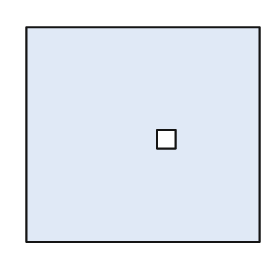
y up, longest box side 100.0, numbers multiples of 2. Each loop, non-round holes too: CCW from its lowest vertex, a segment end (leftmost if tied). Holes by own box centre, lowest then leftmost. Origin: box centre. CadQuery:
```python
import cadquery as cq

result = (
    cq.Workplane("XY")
    .moveTo(-50.0, -46.0)
    .lineTo(50.0, -46.0)
    .lineTo(50.0, 46.0)
    .lineTo(-50.0, 46.0)
    .close()
    .moveTo(6.0, -6.0)
    .lineTo(14.0, -6.0)
    .lineTo(14.0, 2.0)
    .lineTo(6.0, 2.0)
    .close()
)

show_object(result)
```